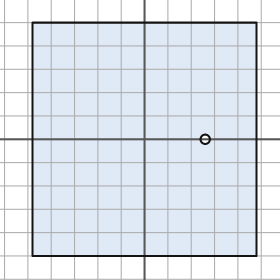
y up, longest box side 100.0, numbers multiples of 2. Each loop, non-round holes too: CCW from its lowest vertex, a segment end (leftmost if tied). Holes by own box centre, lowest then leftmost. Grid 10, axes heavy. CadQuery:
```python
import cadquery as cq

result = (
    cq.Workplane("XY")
    .moveTo(-48.0, -50.0)
    .lineTo(48.0, -50.0)
    .lineTo(48.0, 50.0)
    .lineTo(-48.0, 50.0)
    .close()
    .moveTo(26.0, 0.0)
    .circle(2.0)
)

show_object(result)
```